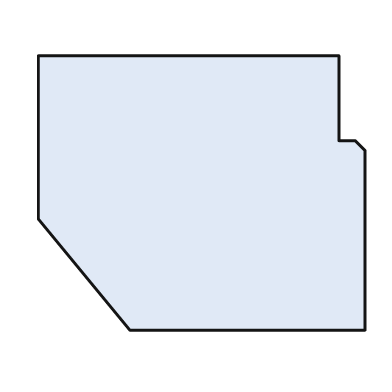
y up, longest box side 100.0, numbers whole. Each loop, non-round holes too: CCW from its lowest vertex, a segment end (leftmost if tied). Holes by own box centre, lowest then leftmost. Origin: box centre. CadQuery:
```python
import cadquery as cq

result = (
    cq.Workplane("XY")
    .moveTo(-22.0, -42.0)
    .lineTo(50.0, -42.0)
    .lineTo(50.0, 13.0)
    .lineTo(47.0, 16.0)
    .lineTo(42.0, 16.0)
    .lineTo(42.0, 42.0)
    .lineTo(-50.0, 42.0)
    .lineTo(-50.0, -8.0)
    .close()
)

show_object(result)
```